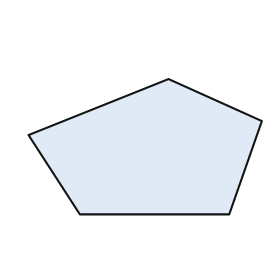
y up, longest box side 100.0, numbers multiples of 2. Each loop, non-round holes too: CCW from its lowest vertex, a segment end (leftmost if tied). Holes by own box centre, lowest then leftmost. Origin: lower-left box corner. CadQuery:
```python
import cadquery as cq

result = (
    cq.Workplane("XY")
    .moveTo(22.0, 0.0)
    .lineTo(86.0, 0.0)
    .lineTo(100.0, 40.0)
    .lineTo(60.0, 58.0)
    .lineTo(0.0, 34.0)
    .close()
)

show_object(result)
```